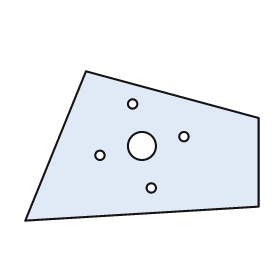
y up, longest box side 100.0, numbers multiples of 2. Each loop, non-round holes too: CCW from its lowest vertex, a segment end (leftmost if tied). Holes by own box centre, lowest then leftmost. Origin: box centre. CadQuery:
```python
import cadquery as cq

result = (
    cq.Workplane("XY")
    .moveTo(-50.0, -32.0)
    .lineTo(50.0, -26.0)
    .lineTo(50.0, 12.0)
    .lineTo(-24.0, 32.0)
    .close()
    .moveTo(4.0, -18.0)
    .circle(2.0)
    .moveTo(-18.0, -4.0)
    .circle(2.0)
    .moveTo(0.0, 0.0)
    .circle(6.0)
    .moveTo(18.0, 4.0)
    .circle(2.0)
    .moveTo(-4.0, 18.0)
    .circle(2.0)
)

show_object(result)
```